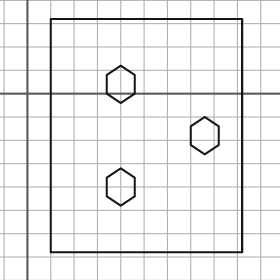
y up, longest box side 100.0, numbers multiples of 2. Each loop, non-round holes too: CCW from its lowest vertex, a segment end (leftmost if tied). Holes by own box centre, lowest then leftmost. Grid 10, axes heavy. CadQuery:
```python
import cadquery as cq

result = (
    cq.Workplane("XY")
    .moveTo(10.0, -68.0)
    .lineTo(92.0, -68.0)
    .lineTo(92.0, 32.0)
    .lineTo(10.0, 32.0)
    .close()
    .moveTo(40.0, -48.0)
    .lineTo(46.0, -44.0)
    .lineTo(46.0, -36.0)
    .lineTo(40.0, -32.0)
    .lineTo(34.0, -36.0)
    .lineTo(34.0, -44.0)
    .close()
    .moveTo(76.0, -26.0)
    .lineTo(82.0, -22.0)
    .lineTo(82.0, -14.0)
    .lineTo(76.0, -10.0)
    .lineTo(70.0, -14.0)
    .lineTo(70.0, -22.0)
    .close()
    .moveTo(40.0, -4.0)
    .lineTo(46.0, 0.0)
    .lineTo(46.0, 8.0)
    .lineTo(40.0, 12.0)
    .lineTo(34.0, 8.0)
    .lineTo(34.0, 0.0)
    .close()
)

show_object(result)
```